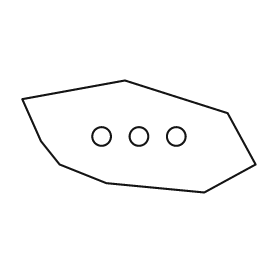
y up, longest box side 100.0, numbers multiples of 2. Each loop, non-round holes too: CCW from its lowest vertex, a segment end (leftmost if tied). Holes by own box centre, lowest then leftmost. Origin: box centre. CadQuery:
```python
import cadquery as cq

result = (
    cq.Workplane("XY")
    .moveTo(28.0, -24.0)
    .lineTo(50.0, -12.0)
    .lineTo(38.0, 10.0)
    .lineTo(-6.0, 24.0)
    .lineTo(-50.0, 16.0)
    .lineTo(-42.0, -2.0)
    .lineTo(-34.0, -12.0)
    .lineTo(-14.0, -20.0)
    .close()
    .moveTo(-16.0, 0.0)
    .circle(4.0)
    .moveTo(0.0, 0.0)
    .circle(4.0)
    .moveTo(16.0, 0.0)
    .circle(4.0)
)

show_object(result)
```